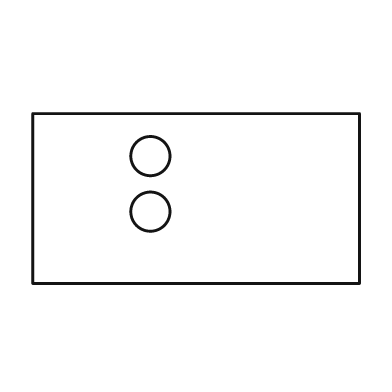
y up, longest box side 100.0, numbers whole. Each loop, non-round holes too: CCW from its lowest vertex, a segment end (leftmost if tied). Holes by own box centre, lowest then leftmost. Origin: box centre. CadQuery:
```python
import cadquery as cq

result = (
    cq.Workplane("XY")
    .moveTo(-50.0, -26.0)
    .lineTo(50.0, -26.0)
    .lineTo(50.0, 26.0)
    .lineTo(-50.0, 26.0)
    .close()
    .moveTo(-14.0, -4.0)
    .circle(6.0)
    .moveTo(-14.0, 13.0)
    .circle(6.0)
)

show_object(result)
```